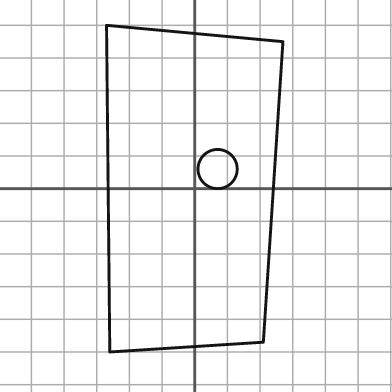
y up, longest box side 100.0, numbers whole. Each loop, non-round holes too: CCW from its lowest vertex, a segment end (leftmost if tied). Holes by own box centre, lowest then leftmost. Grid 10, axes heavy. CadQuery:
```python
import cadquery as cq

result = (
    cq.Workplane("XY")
    .moveTo(-26.0, -50.0)
    .lineTo(21.0, -47.0)
    .lineTo(27.0, 45.0)
    .lineTo(-27.0, 50.0)
    .close()
    .moveTo(7.0, 6.0)
    .circle(6.0)
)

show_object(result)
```